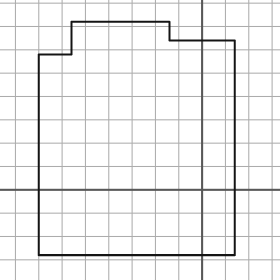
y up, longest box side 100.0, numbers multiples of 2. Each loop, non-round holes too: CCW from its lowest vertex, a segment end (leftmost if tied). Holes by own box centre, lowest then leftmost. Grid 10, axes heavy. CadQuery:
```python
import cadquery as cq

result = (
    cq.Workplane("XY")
    .moveTo(-70.0, -28.0)
    .lineTo(14.0, -28.0)
    .lineTo(14.0, 64.0)
    .lineTo(-14.0, 64.0)
    .lineTo(-14.0, 72.0)
    .lineTo(-56.0, 72.0)
    .lineTo(-56.0, 58.0)
    .lineTo(-70.0, 58.0)
    .close()
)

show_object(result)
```